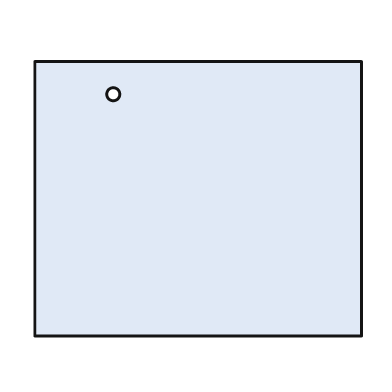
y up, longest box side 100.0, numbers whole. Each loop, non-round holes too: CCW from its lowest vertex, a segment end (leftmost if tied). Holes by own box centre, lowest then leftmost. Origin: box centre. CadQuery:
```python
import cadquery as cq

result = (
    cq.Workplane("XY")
    .moveTo(-50.0, -42.0)
    .lineTo(50.0, -42.0)
    .lineTo(50.0, 42.0)
    .lineTo(-50.0, 42.0)
    .close()
    .moveTo(-26.0, 32.0)
    .circle(2.0)
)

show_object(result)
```